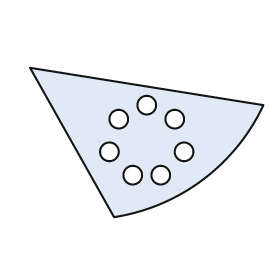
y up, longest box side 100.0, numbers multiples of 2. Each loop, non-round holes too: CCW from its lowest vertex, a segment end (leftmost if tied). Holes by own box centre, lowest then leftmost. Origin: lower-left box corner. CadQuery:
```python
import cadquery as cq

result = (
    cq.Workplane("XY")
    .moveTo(36.0, 0.0)
    .threePointArc((74.0, 16.0), (100.0, 48.0))
    .lineTo(0.0, 64.0)
    .close()
    .moveTo(44.0, 18.0)
    .circle(4.0)
    .moveTo(56.0, 18.0)
    .circle(4.0)
    .moveTo(34.0, 28.0)
    .circle(4.0)
    .moveTo(66.0, 28.0)
    .circle(4.0)
    .moveTo(38.0, 42.0)
    .circle(4.0)
    .moveTo(62.0, 42.0)
    .circle(4.0)
    .moveTo(50.0, 48.0)
    .circle(4.0)
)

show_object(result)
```